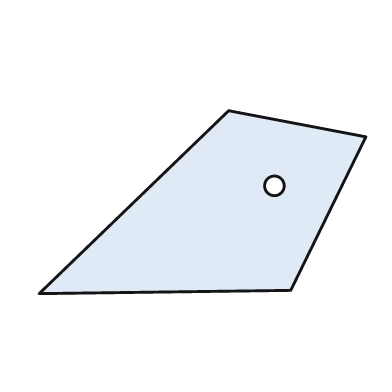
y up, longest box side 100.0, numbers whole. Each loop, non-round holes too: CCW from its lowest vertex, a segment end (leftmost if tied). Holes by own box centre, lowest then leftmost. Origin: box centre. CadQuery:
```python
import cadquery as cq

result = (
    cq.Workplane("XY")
    .moveTo(-50.0, -28.0)
    .lineTo(27.0, -27.0)
    .lineTo(50.0, 20.0)
    .lineTo(8.0, 28.0)
    .close()
    .moveTo(22.0, 5.0)
    .circle(3.0)
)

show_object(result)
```